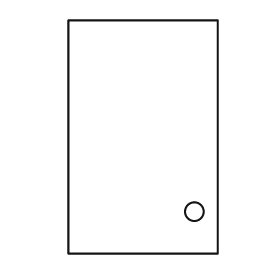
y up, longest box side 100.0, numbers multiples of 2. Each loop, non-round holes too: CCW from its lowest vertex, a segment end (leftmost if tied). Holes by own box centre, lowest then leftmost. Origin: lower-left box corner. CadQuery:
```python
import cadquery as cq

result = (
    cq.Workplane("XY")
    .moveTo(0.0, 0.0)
    .lineTo(64.0, 0.0)
    .lineTo(64.0, 100.0)
    .lineTo(0.0, 100.0)
    .close()
    .moveTo(54.0, 18.0)
    .circle(4.0)
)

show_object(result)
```